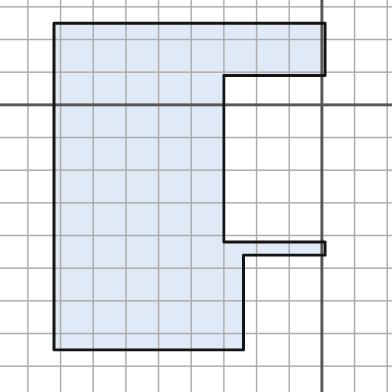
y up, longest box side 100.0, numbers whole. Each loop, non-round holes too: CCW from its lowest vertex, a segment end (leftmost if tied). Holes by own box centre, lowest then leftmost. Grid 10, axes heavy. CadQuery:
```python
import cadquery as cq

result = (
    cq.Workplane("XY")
    .moveTo(-82.0, -75.0)
    .lineTo(-24.0, -75.0)
    .lineTo(-24.0, -46.0)
    .lineTo(1.0, -46.0)
    .lineTo(1.0, -42.0)
    .lineTo(-30.0, -42.0)
    .lineTo(-30.0, 9.0)
    .lineTo(1.0, 9.0)
    .lineTo(1.0, 25.0)
    .lineTo(-82.0, 25.0)
    .close()
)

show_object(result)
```